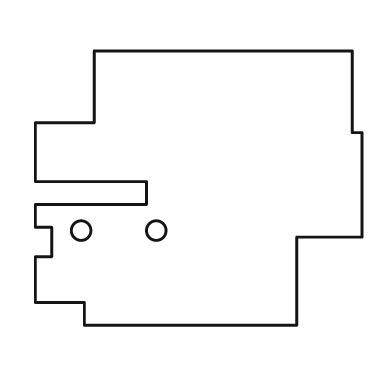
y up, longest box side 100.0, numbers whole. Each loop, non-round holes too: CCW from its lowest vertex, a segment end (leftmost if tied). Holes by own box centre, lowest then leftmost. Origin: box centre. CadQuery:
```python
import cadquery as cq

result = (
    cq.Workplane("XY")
    .moveTo(-35.0, -42.0)
    .lineTo(30.0, -42.0)
    .lineTo(30.0, -15.0)
    .lineTo(50.0, -15.0)
    .lineTo(50.0, 17.0)
    .lineTo(47.0, 17.0)
    .lineTo(47.0, 42.0)
    .lineTo(-32.0, 42.0)
    .lineTo(-32.0, 20.0)
    .lineTo(-50.0, 20.0)
    .lineTo(-50.0, 2.0)
    .lineTo(-16.0, 2.0)
    .lineTo(-16.0, -5.0)
    .lineTo(-50.0, -5.0)
    .lineTo(-50.0, -12.0)
    .lineTo(-45.0, -12.0)
    .lineTo(-45.0, -21.0)
    .lineTo(-50.0, -21.0)
    .lineTo(-50.0, -35.0)
    .lineTo(-35.0, -35.0)
    .close()
    .moveTo(-36.0, -13.0)
    .circle(3.0)
    .moveTo(-13.0, -13.0)
    .circle(3.0)
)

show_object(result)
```